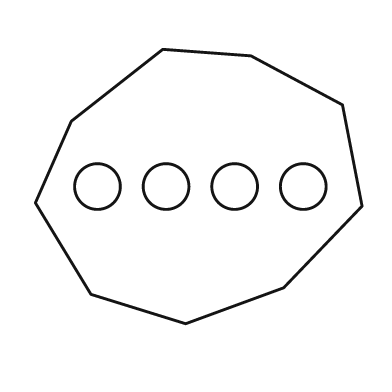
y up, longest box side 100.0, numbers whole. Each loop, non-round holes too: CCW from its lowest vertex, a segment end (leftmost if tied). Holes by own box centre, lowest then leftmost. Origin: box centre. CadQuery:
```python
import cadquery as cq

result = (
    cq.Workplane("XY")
    .moveTo(-4.0, -42.0)
    .lineTo(26.0, -31.0)
    .lineTo(50.0, -6.0)
    .lineTo(44.0, 25.0)
    .lineTo(16.0, 40.0)
    .lineTo(-11.0, 42.0)
    .lineTo(-39.0, 20.0)
    .lineTo(-50.0, -5.0)
    .lineTo(-33.0, -33.0)
    .close()
    .moveTo(-31.0, 0.0)
    .circle(7.0)
    .moveTo(-10.0, 0.0)
    .circle(7.0)
    .moveTo(11.0, 0.0)
    .circle(7.0)
    .moveTo(32.0, 0.0)
    .circle(7.0)
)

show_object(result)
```